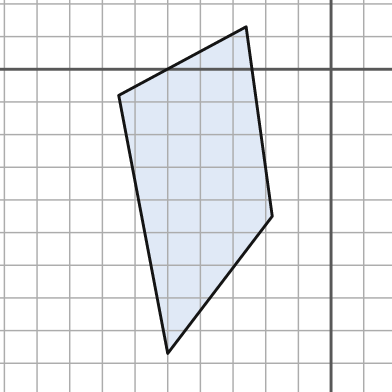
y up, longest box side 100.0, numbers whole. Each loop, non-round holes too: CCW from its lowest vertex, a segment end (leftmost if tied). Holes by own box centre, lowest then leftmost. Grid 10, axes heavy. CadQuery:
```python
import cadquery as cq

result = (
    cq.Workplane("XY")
    .moveTo(-50.0, -87.0)
    .lineTo(-18.0, -45.0)
    .lineTo(-26.0, 13.0)
    .lineTo(-65.0, -8.0)
    .close()
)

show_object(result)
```